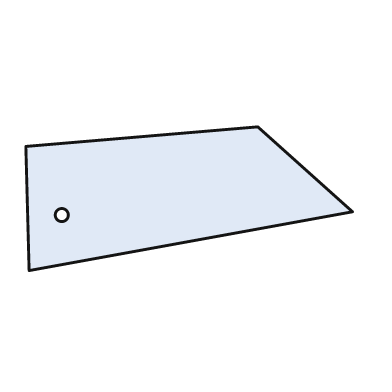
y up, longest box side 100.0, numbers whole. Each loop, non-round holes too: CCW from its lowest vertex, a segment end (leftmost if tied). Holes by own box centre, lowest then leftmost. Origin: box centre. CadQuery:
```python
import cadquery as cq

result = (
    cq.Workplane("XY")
    .moveTo(-49.0, -22.0)
    .lineTo(50.0, -4.0)
    .lineTo(21.0, 22.0)
    .lineTo(-50.0, 16.0)
    .close()
    .moveTo(-39.0, -5.0)
    .circle(2.0)
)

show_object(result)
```